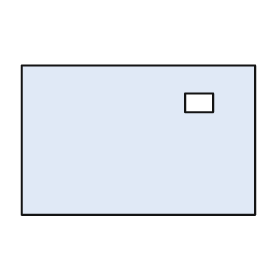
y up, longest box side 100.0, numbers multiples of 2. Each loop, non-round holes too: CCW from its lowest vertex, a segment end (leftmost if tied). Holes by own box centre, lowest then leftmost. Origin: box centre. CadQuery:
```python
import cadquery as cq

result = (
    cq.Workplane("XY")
    .moveTo(-50.0, -32.0)
    .lineTo(50.0, -32.0)
    .lineTo(50.0, 32.0)
    .lineTo(-50.0, 32.0)
    .close()
    .moveTo(20.0, 12.0)
    .lineTo(32.0, 12.0)
    .lineTo(32.0, 20.0)
    .lineTo(20.0, 20.0)
    .close()
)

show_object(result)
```